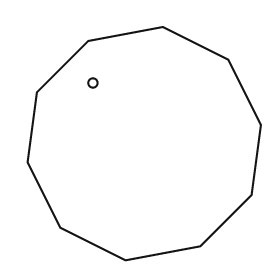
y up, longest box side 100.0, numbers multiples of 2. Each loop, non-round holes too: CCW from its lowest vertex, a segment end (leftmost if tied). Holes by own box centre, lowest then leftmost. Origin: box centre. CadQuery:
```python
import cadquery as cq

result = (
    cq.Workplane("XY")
    .moveTo(-8.0, -50.0)
    .lineTo(24.0, -44.0)
    .lineTo(46.0, -22.0)
    .lineTo(50.0, 8.0)
    .lineTo(36.0, 36.0)
    .lineTo(8.0, 50.0)
    .lineTo(-24.0, 44.0)
    .lineTo(-46.0, 22.0)
    .lineTo(-50.0, -8.0)
    .lineTo(-36.0, -36.0)
    .close()
    .moveTo(-22.0, 26.0)
    .circle(2.0)
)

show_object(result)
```